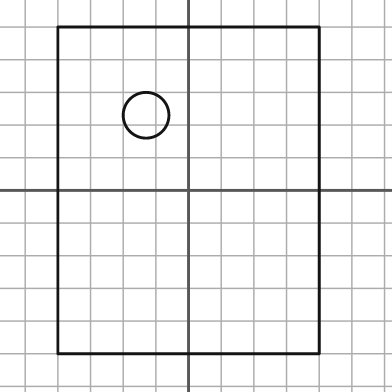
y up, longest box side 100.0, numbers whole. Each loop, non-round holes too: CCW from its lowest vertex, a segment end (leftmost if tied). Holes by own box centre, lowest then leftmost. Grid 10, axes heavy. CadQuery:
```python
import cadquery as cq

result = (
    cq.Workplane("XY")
    .moveTo(-40.0, -50.0)
    .lineTo(40.0, -50.0)
    .lineTo(40.0, 50.0)
    .lineTo(-40.0, 50.0)
    .close()
    .moveTo(-13.0, 23.0)
    .circle(7.0)
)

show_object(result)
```